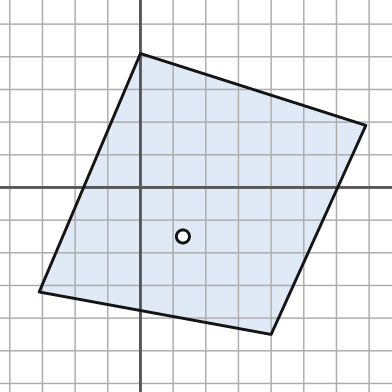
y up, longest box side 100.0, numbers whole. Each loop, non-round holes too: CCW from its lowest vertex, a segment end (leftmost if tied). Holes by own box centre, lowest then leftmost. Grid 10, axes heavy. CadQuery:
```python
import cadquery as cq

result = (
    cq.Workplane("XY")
    .moveTo(40.0, -45.0)
    .lineTo(69.0, 19.0)
    .lineTo(0.0, 41.0)
    .lineTo(-31.0, -32.0)
    .close()
    .moveTo(13.0, -15.0)
    .circle(2.0)
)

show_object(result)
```